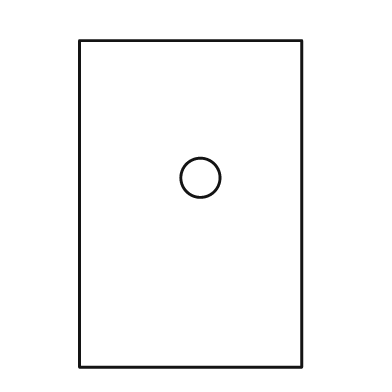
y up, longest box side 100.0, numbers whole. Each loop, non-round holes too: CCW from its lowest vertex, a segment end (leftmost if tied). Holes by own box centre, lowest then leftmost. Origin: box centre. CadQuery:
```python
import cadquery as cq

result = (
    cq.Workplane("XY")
    .moveTo(-34.0, -50.0)
    .lineTo(34.0, -50.0)
    .lineTo(34.0, 50.0)
    .lineTo(-34.0, 50.0)
    .close()
    .moveTo(3.0, 8.0)
    .circle(6.0)
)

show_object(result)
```